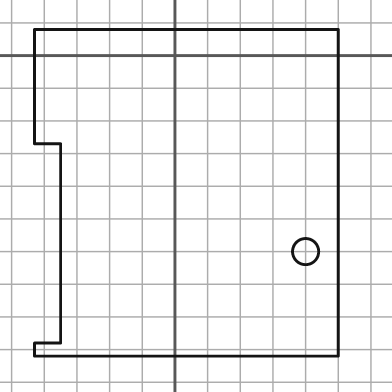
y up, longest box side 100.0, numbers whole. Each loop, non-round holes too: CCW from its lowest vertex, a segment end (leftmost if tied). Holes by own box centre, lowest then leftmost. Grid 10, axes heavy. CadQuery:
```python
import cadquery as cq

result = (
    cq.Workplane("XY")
    .moveTo(-43.0, -92.0)
    .lineTo(50.0, -92.0)
    .lineTo(50.0, 8.0)
    .lineTo(-43.0, 8.0)
    .lineTo(-43.0, -27.0)
    .lineTo(-35.0, -27.0)
    .lineTo(-35.0, -88.0)
    .lineTo(-43.0, -88.0)
    .close()
    .moveTo(40.0, -60.0)
    .circle(4.0)
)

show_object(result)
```